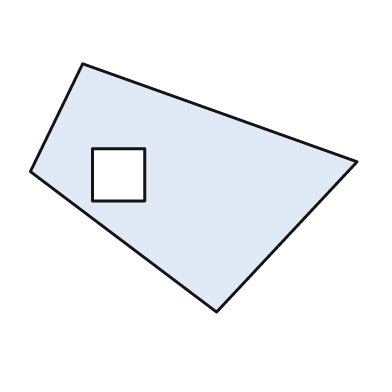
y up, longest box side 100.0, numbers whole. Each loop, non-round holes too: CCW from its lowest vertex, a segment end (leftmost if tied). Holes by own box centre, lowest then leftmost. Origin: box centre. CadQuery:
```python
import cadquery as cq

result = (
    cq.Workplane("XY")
    .moveTo(7.0, -38.0)
    .lineTo(50.0, 8.0)
    .lineTo(-34.0, 38.0)
    .lineTo(-50.0, 5.0)
    .close()
    .moveTo(-31.0, -4.0)
    .lineTo(-15.0, -4.0)
    .lineTo(-15.0, 12.0)
    .lineTo(-31.0, 12.0)
    .close()
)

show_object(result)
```